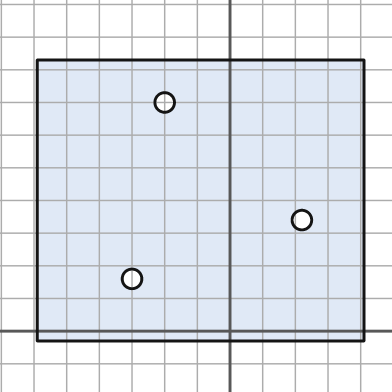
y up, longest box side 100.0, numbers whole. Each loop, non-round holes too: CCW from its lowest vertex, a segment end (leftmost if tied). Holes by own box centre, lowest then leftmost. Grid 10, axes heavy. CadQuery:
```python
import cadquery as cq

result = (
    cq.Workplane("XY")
    .moveTo(-59.0, -3.0)
    .lineTo(41.0, -3.0)
    .lineTo(41.0, 83.0)
    .lineTo(-59.0, 83.0)
    .close()
    .moveTo(-30.0, 16.0)
    .circle(3.0)
    .moveTo(22.0, 34.0)
    .circle(3.0)
    .moveTo(-20.0, 70.0)
    .circle(3.0)
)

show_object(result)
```